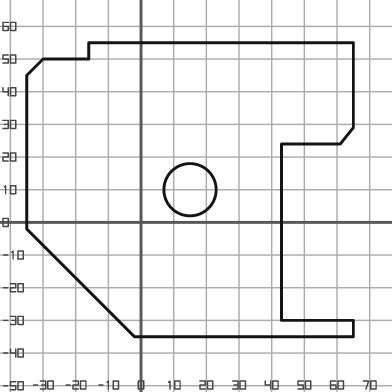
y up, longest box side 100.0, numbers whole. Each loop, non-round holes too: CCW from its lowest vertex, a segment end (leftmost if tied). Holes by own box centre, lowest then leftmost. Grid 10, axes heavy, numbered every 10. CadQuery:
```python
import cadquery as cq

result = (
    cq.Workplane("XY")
    .moveTo(-2.0, -35.0)
    .lineTo(65.0, -35.0)
    .lineTo(65.0, -30.0)
    .lineTo(43.0, -30.0)
    .lineTo(43.0, 24.0)
    .lineTo(61.0, 24.0)
    .lineTo(65.0, 29.0)
    .lineTo(65.0, 55.0)
    .lineTo(-16.0, 55.0)
    .lineTo(-16.0, 50.0)
    .lineTo(-30.0, 50.0)
    .lineTo(-35.0, 45.0)
    .lineTo(-35.0, -2.0)
    .close()
    .moveTo(15.0, 10.0)
    .circle(8.0)
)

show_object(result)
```